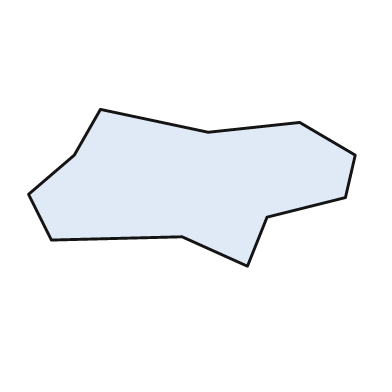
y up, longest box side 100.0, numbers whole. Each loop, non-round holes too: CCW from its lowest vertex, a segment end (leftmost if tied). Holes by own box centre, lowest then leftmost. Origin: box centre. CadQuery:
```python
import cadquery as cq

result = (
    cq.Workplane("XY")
    .moveTo(17.0, -24.0)
    .lineTo(23.0, -9.0)
    .lineTo(47.0, -3.0)
    .lineTo(50.0, 10.0)
    .lineTo(33.0, 20.0)
    .lineTo(5.0, 17.0)
    .lineTo(-28.0, 24.0)
    .lineTo(-36.0, 10.0)
    .lineTo(-50.0, -2.0)
    .lineTo(-43.0, -16.0)
    .lineTo(-3.0, -15.0)
    .close()
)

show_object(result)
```